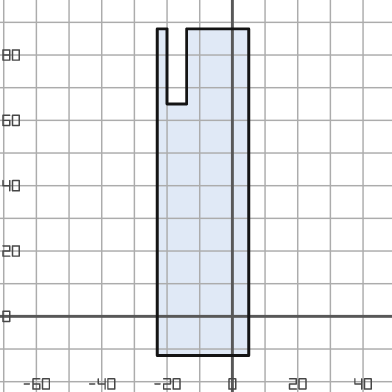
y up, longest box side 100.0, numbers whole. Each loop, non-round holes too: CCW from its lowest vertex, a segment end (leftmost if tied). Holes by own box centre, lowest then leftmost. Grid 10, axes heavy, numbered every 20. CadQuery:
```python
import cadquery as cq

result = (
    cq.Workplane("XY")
    .moveTo(-23.0, -12.0)
    .lineTo(5.0, -12.0)
    .lineTo(5.0, 88.0)
    .lineTo(-14.0, 88.0)
    .lineTo(-14.0, 65.0)
    .lineTo(-20.0, 65.0)
    .lineTo(-20.0, 88.0)
    .lineTo(-23.0, 88.0)
    .close()
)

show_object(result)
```